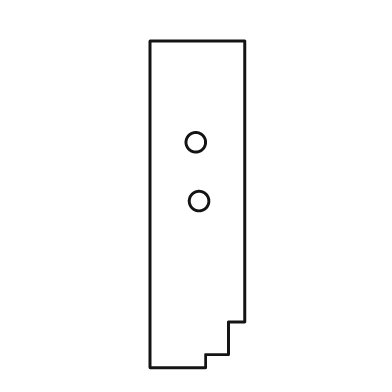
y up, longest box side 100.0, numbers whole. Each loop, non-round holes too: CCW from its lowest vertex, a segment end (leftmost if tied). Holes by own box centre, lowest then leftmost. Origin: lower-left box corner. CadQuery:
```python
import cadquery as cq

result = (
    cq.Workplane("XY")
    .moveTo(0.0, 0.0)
    .lineTo(17.0, 0.0)
    .lineTo(17.0, 4.0)
    .lineTo(24.0, 4.0)
    .lineTo(24.0, 14.0)
    .lineTo(29.0, 14.0)
    .lineTo(29.0, 100.0)
    .lineTo(0.0, 100.0)
    .close()
    .moveTo(15.0, 51.0)
    .circle(3.0)
    .moveTo(14.0, 69.0)
    .circle(3.0)
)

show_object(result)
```